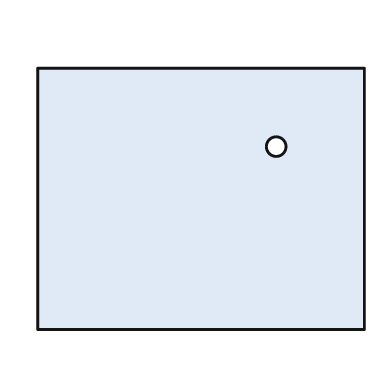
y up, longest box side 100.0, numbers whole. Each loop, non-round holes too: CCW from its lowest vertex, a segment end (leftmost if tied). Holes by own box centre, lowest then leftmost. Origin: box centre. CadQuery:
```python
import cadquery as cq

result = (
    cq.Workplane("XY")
    .moveTo(-50.0, -40.0)
    .lineTo(50.0, -40.0)
    .lineTo(50.0, 40.0)
    .lineTo(-50.0, 40.0)
    .close()
    .moveTo(23.0, 16.0)
    .circle(3.0)
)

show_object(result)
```